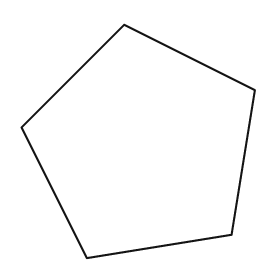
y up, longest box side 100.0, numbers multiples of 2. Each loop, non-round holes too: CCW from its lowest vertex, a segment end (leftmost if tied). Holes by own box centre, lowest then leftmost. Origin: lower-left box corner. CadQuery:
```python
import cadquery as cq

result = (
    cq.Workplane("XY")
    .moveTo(28.0, 0.0)
    .lineTo(90.0, 10.0)
    .lineTo(100.0, 72.0)
    .lineTo(44.0, 100.0)
    .lineTo(0.0, 56.0)
    .close()
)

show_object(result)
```